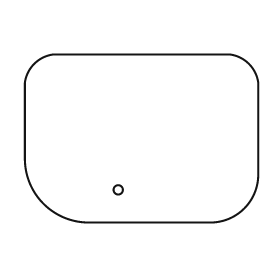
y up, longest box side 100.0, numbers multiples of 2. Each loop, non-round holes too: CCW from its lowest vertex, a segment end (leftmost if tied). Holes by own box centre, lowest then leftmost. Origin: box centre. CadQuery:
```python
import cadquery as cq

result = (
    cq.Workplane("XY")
    .moveTo(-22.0, -36.0)
    .lineTo(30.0, -36.0)
    .threePointArc((44.0, -30.0), (50.0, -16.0))
    .lineTo(50.0, 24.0)
    .threePointArc((46.0, 32.0), (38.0, 36.0))
    .lineTo(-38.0, 36.0)
    .threePointArc((-46.0, 32.0), (-50.0, 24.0))
    .lineTo(-50.0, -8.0)
    .threePointArc((-42.0, -28.0), (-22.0, -36.0))
    .close()
    .moveTo(-10.0, -22.0)
    .circle(2.0)
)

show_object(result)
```